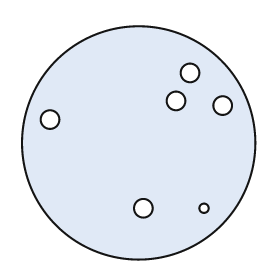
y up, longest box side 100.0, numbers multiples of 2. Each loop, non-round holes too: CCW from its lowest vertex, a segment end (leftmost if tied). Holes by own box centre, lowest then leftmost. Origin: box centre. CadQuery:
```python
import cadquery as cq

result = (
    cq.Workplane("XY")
    .moveTo(0.0, 0.0)
    .circle(50.0)
    .moveTo(2.0, -28.0)
    .circle(4.0)
    .moveTo(28.0, -28.0)
    .circle(2.0)
    .moveTo(-38.0, 10.0)
    .circle(4.0)
    .moveTo(36.0, 16.0)
    .circle(4.0)
    .moveTo(16.0, 18.0)
    .circle(4.0)
    .moveTo(22.0, 30.0)
    .circle(4.0)
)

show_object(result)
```